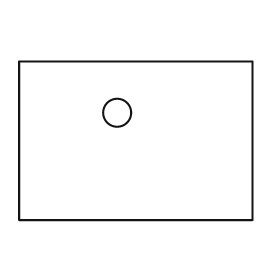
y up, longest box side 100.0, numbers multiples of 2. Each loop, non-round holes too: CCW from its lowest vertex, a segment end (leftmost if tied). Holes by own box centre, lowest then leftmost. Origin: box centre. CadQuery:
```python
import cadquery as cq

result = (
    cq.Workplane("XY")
    .moveTo(-50.0, -34.0)
    .lineTo(50.0, -34.0)
    .lineTo(50.0, 34.0)
    .lineTo(-50.0, 34.0)
    .close()
    .moveTo(-8.0, 12.0)
    .circle(6.0)
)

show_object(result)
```